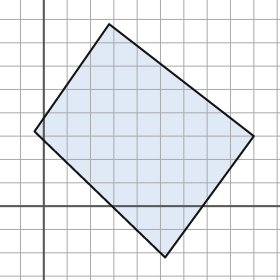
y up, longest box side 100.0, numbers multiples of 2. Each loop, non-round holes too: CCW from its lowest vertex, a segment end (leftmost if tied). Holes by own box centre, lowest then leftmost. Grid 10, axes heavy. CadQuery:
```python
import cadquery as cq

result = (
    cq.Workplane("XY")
    .moveTo(52.0, -22.0)
    .lineTo(90.0, 30.0)
    .lineTo(28.0, 78.0)
    .lineTo(-4.0, 32.0)
    .close()
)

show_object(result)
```